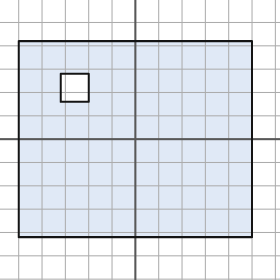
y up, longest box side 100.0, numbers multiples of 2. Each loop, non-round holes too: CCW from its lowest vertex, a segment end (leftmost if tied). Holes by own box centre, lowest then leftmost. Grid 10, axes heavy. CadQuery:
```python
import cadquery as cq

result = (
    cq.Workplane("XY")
    .moveTo(-50.0, -42.0)
    .lineTo(50.0, -42.0)
    .lineTo(50.0, 42.0)
    .lineTo(-50.0, 42.0)
    .close()
    .moveTo(-32.0, 16.0)
    .lineTo(-20.0, 16.0)
    .lineTo(-20.0, 28.0)
    .lineTo(-32.0, 28.0)
    .close()
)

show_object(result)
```